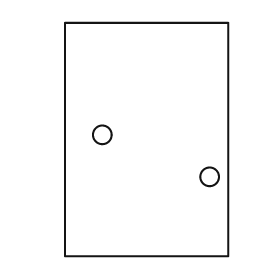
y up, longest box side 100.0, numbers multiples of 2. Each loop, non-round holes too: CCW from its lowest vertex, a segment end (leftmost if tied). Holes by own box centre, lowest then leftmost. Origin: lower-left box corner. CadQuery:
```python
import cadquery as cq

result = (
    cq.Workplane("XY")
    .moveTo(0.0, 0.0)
    .lineTo(70.0, 0.0)
    .lineTo(70.0, 100.0)
    .lineTo(0.0, 100.0)
    .close()
    .moveTo(62.0, 34.0)
    .circle(4.0)
    .moveTo(16.0, 52.0)
    .circle(4.0)
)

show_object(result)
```